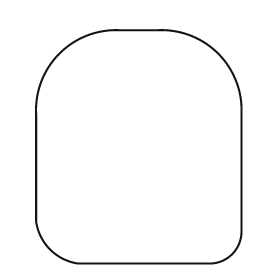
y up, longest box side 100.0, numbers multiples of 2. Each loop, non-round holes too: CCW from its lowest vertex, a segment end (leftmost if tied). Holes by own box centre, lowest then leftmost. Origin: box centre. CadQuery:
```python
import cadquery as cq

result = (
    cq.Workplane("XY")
    .moveTo(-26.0, -50.0)
    .lineTo(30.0, -50.0)
    .threePointArc((40.0, -46.0), (44.0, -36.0))
    .lineTo(44.0, 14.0)
    .threePointArc((34.0, 40.0), (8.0, 50.0))
    .lineTo(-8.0, 50.0)
    .threePointArc((-34.0, 40.0), (-44.0, 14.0))
    .lineTo(-44.0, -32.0)
    .threePointArc((-38.0, -44.0), (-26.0, -50.0))
    .close()
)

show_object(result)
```